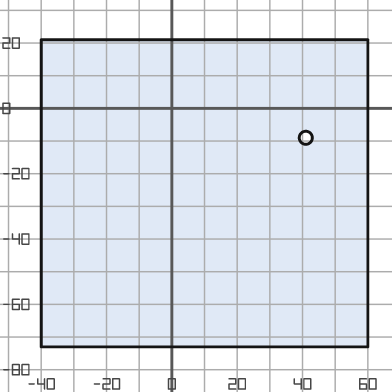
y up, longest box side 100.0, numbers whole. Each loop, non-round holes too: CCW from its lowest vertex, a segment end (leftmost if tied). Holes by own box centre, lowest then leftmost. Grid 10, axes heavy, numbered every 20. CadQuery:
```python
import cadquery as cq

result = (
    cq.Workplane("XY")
    .moveTo(-40.0, -73.0)
    .lineTo(60.0, -73.0)
    .lineTo(60.0, 21.0)
    .lineTo(-40.0, 21.0)
    .close()
    .moveTo(41.0, -9.0)
    .circle(2.0)
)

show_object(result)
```